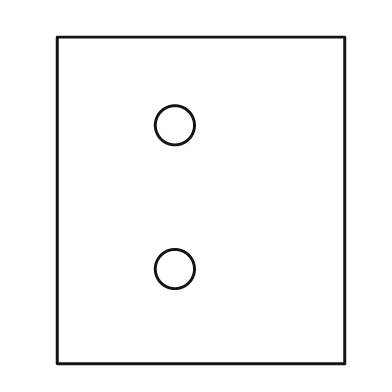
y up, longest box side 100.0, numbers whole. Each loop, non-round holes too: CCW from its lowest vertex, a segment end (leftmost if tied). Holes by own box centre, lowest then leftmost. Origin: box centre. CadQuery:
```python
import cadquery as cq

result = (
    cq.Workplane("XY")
    .moveTo(-44.0, -50.0)
    .lineTo(44.0, -50.0)
    .lineTo(44.0, 50.0)
    .lineTo(-44.0, 50.0)
    .close()
    .moveTo(-8.0, -21.0)
    .circle(6.0)
    .moveTo(-8.0, 23.0)
    .circle(6.0)
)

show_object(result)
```